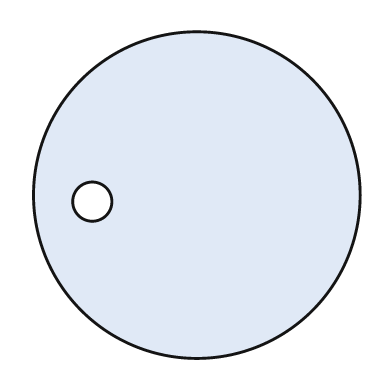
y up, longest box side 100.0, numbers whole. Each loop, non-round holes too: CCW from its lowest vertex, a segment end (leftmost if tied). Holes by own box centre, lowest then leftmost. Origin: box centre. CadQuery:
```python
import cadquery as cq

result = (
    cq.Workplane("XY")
    .moveTo(0.0, 0.0)
    .circle(50.0)
    .moveTo(-32.0, -2.0)
    .circle(6.0)
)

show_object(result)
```